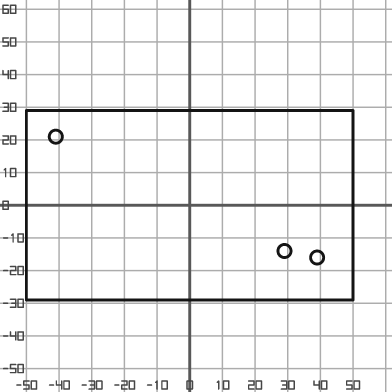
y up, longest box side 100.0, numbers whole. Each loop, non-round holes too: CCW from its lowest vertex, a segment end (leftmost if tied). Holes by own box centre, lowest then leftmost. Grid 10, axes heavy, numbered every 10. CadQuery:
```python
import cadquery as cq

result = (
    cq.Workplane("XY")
    .moveTo(-50.0, -29.0)
    .lineTo(50.0, -29.0)
    .lineTo(50.0, 29.0)
    .lineTo(-50.0, 29.0)
    .close()
    .moveTo(39.0, -16.0)
    .circle(2.0)
    .moveTo(29.0, -14.0)
    .circle(2.0)
    .moveTo(-41.0, 21.0)
    .circle(2.0)
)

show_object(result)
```